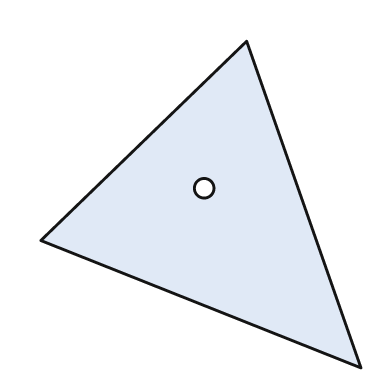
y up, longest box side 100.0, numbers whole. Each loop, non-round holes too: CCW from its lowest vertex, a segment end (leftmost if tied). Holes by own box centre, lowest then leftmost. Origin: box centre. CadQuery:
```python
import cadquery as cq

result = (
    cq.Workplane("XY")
    .moveTo(49.0, -50.0)
    .lineTo(14.0, 50.0)
    .lineTo(-49.0, -11.0)
    .close()
    .moveTo(1.0, 5.0)
    .circle(3.0)
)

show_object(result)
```